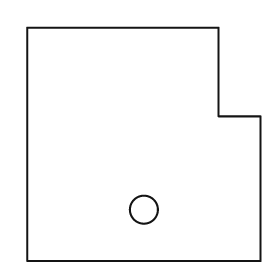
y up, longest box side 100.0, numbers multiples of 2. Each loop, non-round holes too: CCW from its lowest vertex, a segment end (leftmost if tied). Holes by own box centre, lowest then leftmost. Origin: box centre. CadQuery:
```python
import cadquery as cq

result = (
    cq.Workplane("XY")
    .moveTo(-50.0, -50.0)
    .lineTo(50.0, -50.0)
    .lineTo(50.0, 12.0)
    .lineTo(32.0, 12.0)
    .lineTo(32.0, 50.0)
    .lineTo(-50.0, 50.0)
    .close()
    .moveTo(0.0, -28.0)
    .circle(6.0)
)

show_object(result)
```